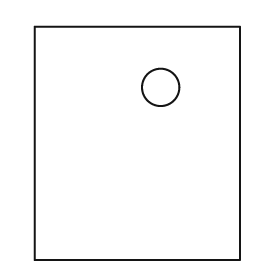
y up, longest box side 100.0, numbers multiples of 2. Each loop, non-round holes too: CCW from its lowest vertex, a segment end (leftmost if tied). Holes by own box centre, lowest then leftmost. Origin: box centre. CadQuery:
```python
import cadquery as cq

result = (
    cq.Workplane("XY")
    .moveTo(-44.0, -50.0)
    .lineTo(44.0, -50.0)
    .lineTo(44.0, 50.0)
    .lineTo(-44.0, 50.0)
    .close()
    .moveTo(10.0, 24.0)
    .circle(8.0)
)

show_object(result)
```